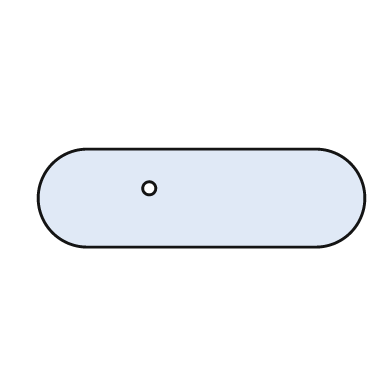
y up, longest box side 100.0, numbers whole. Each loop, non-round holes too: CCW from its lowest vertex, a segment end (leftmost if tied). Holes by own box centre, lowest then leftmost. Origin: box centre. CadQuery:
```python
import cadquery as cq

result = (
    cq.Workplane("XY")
    .moveTo(-35.0, -15.0)
    .lineTo(35.0, -15.0)
    .threePointArc((50.0, 0.0), (35.0, 15.0))
    .lineTo(-35.0, 15.0)
    .threePointArc((-50.0, 0.0), (-35.0, -15.0))
    .close()
    .moveTo(-16.0, 3.0)
    .circle(2.0)
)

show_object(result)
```